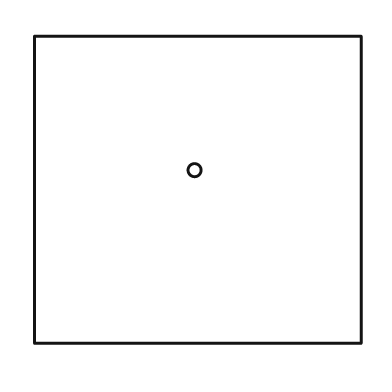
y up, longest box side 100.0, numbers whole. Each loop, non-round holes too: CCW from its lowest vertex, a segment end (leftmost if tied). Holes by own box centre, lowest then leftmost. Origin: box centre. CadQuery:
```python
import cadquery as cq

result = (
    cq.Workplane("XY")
    .moveTo(-50.0, -47.0)
    .lineTo(50.0, -47.0)
    .lineTo(50.0, 47.0)
    .lineTo(-50.0, 47.0)
    .close()
    .moveTo(-1.0, 6.0)
    .circle(2.0)
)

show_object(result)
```